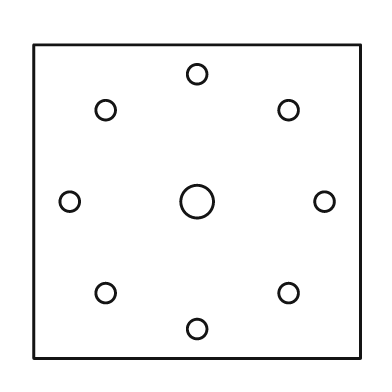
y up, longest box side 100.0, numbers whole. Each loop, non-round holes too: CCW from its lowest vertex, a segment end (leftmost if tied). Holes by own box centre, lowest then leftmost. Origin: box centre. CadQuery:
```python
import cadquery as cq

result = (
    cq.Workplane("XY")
    .moveTo(-50.0, -48.0)
    .lineTo(50.0, -48.0)
    .lineTo(50.0, 48.0)
    .lineTo(-50.0, 48.0)
    .close()
    .moveTo(0.0, -39.0)
    .circle(3.0)
    .moveTo(-28.0, -28.0)
    .circle(3.0)
    .moveTo(28.0, -28.0)
    .circle(3.0)
    .moveTo(-39.0, 0.0)
    .circle(3.0)
    .moveTo(0.0, 0.0)
    .circle(5.0)
    .moveTo(39.0, 0.0)
    .circle(3.0)
    .moveTo(-28.0, 28.0)
    .circle(3.0)
    .moveTo(28.0, 28.0)
    .circle(3.0)
    .moveTo(0.0, 39.0)
    .circle(3.0)
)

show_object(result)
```